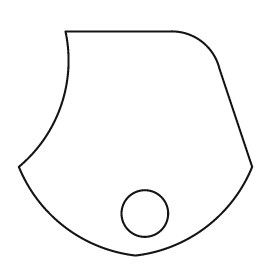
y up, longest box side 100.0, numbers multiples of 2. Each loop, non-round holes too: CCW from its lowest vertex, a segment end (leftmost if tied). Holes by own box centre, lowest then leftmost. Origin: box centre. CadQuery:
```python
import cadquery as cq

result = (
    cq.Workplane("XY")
    .moveTo(0.0, -48.0)
    .threePointArc((30.0, -36.0), (50.0, -10.0))
    .lineTo(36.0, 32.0)
    .threePointArc((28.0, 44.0), (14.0, 48.0))
    .lineTo(-30.0, 48.0)
    .threePointArc((-32.0, 16.0), (-50.0, -10.0))
    .threePointArc((-30.0, -36.0), (0.0, -48.0))
    .close()
    .moveTo(4.0, -30.0)
    .circle(10.0)
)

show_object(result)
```